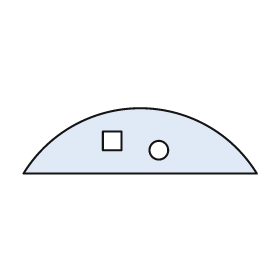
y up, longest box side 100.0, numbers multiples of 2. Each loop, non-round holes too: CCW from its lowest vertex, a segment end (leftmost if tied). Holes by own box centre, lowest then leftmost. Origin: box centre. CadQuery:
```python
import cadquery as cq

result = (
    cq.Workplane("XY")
    .moveTo(-50.0, -14.0)
    .lineTo(50.0, -14.0)
    .threePointArc((0.0, 14.0), (-50.0, -14.0))
    .close()
    .moveTo(8.0, -4.0)
    .circle(4.0)
    .moveTo(-16.0, -4.0)
    .lineTo(-8.0, -4.0)
    .lineTo(-8.0, 4.0)
    .lineTo(-16.0, 4.0)
    .close()
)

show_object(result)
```